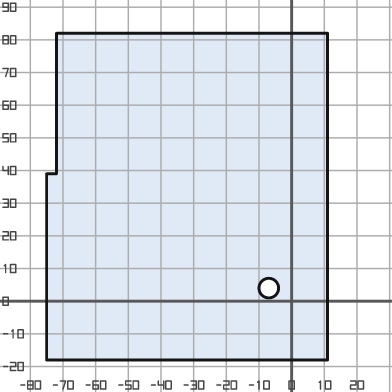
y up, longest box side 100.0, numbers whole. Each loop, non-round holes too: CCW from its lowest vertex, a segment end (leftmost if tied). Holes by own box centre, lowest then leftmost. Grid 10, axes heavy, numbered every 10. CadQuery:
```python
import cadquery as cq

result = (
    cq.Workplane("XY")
    .moveTo(-75.0, -18.0)
    .lineTo(11.0, -18.0)
    .lineTo(11.0, 82.0)
    .lineTo(-72.0, 82.0)
    .lineTo(-72.0, 39.0)
    .lineTo(-75.0, 39.0)
    .close()
    .moveTo(-7.0, 4.0)
    .circle(3.0)
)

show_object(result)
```